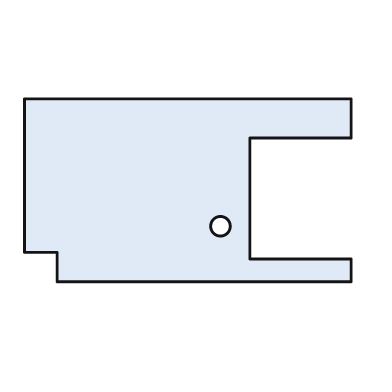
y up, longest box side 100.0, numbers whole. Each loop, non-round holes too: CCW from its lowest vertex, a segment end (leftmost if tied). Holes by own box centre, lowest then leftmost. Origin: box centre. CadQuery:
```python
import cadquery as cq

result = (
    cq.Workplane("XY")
    .moveTo(-40.0, -28.0)
    .lineTo(50.0, -28.0)
    .lineTo(50.0, -21.0)
    .lineTo(19.0, -21.0)
    .lineTo(19.0, 16.0)
    .lineTo(50.0, 16.0)
    .lineTo(50.0, 28.0)
    .lineTo(-50.0, 28.0)
    .lineTo(-50.0, -19.0)
    .lineTo(-40.0, -19.0)
    .close()
    .moveTo(10.0, -11.0)
    .circle(3.0)
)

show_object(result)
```